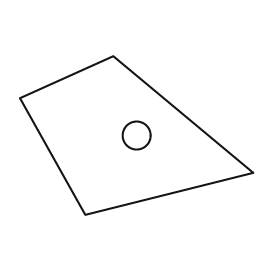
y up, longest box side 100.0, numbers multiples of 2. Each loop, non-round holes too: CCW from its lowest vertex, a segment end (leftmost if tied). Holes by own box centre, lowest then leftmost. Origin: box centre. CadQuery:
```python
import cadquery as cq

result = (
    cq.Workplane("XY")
    .moveTo(-22.0, -34.0)
    .lineTo(50.0, -16.0)
    .lineTo(-10.0, 34.0)
    .lineTo(-50.0, 16.0)
    .close()
    .moveTo(0.0, 0.0)
    .circle(6.0)
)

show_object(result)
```